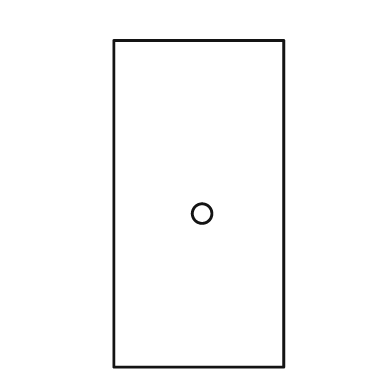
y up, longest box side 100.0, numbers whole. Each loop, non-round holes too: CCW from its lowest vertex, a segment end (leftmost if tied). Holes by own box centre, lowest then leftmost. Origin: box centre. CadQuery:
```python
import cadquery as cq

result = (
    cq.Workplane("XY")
    .moveTo(-26.0, -50.0)
    .lineTo(26.0, -50.0)
    .lineTo(26.0, 50.0)
    .lineTo(-26.0, 50.0)
    .close()
    .moveTo(1.0, -3.0)
    .circle(3.0)
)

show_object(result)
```